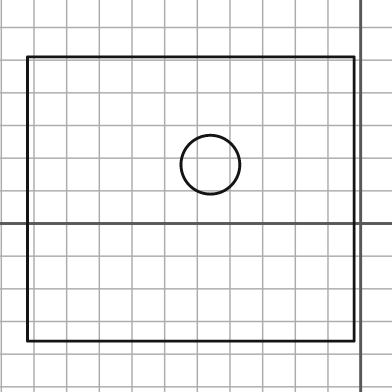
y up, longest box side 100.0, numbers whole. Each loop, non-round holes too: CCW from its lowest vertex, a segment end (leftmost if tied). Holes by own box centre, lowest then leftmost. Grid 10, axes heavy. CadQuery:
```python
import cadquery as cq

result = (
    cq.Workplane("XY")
    .moveTo(-102.0, -36.0)
    .lineTo(-2.0, -36.0)
    .lineTo(-2.0, 51.0)
    .lineTo(-102.0, 51.0)
    .close()
    .moveTo(-46.0, 18.0)
    .circle(9.0)
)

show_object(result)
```